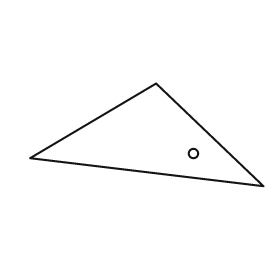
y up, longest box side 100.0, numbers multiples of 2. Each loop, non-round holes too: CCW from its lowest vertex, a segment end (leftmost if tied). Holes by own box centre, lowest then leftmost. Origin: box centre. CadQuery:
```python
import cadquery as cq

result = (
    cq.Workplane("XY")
    .moveTo(50.0, -22.0)
    .lineTo(4.0, 22.0)
    .lineTo(-50.0, -10.0)
    .close()
    .moveTo(20.0, -8.0)
    .circle(2.0)
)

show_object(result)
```